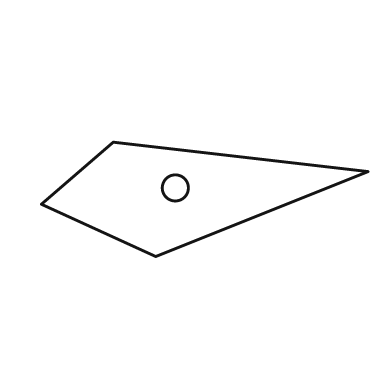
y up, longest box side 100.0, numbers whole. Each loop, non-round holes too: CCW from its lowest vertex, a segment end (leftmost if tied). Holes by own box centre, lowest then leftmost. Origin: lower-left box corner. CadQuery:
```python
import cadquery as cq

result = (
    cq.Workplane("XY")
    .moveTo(35.0, 0.0)
    .lineTo(100.0, 26.0)
    .lineTo(22.0, 35.0)
    .lineTo(0.0, 16.0)
    .close()
    .moveTo(41.0, 21.0)
    .circle(4.0)
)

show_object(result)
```